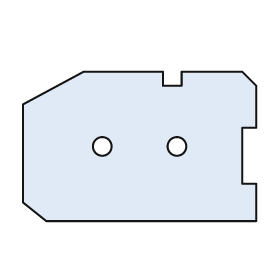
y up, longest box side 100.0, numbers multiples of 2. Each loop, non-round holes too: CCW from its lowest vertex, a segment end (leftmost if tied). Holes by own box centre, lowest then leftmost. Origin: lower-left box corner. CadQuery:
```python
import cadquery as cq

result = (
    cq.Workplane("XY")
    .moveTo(10.0, 0.0)
    .lineTo(100.0, 0.0)
    .lineTo(100.0, 16.0)
    .lineTo(94.0, 16.0)
    .lineTo(94.0, 40.0)
    .lineTo(100.0, 40.0)
    .lineTo(100.0, 58.0)
    .lineTo(94.0, 64.0)
    .lineTo(68.0, 64.0)
    .lineTo(68.0, 58.0)
    .lineTo(60.0, 58.0)
    .lineTo(60.0, 64.0)
    .lineTo(26.0, 64.0)
    .lineTo(0.0, 50.0)
    .lineTo(0.0, 8.0)
    .close()
    .moveTo(34.0, 32.0)
    .circle(4.0)
    .moveTo(66.0, 32.0)
    .circle(4.0)
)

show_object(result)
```